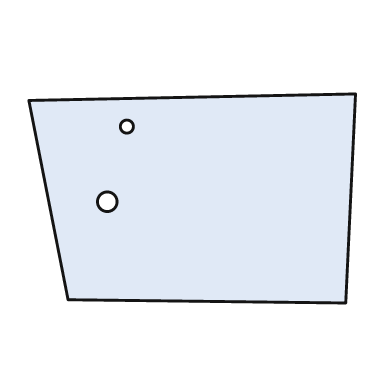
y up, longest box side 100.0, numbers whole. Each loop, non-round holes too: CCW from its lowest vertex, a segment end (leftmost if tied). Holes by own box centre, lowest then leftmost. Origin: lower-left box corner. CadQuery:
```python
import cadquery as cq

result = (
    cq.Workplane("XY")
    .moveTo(97.0, 0.0)
    .lineTo(100.0, 64.0)
    .lineTo(0.0, 62.0)
    .lineTo(12.0, 1.0)
    .close()
    .moveTo(24.0, 31.0)
    .circle(3.0)
    .moveTo(30.0, 54.0)
    .circle(2.0)
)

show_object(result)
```